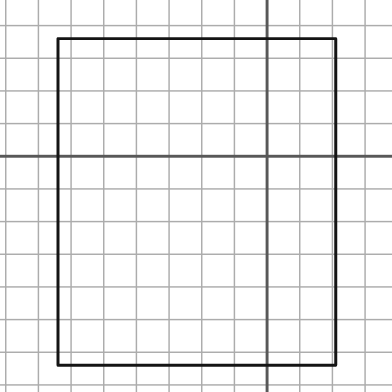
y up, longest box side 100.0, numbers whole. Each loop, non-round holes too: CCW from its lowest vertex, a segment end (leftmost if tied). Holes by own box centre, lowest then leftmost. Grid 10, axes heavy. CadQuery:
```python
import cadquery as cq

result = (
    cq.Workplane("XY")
    .moveTo(-64.0, -64.0)
    .lineTo(21.0, -64.0)
    .lineTo(21.0, 36.0)
    .lineTo(-64.0, 36.0)
    .close()
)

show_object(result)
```